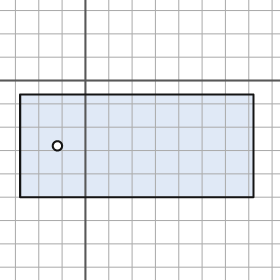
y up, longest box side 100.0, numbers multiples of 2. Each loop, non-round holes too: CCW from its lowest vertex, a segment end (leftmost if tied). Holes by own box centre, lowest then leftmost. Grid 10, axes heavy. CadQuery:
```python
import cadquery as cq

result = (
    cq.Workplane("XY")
    .moveTo(-28.0, -50.0)
    .lineTo(72.0, -50.0)
    .lineTo(72.0, -6.0)
    .lineTo(-28.0, -6.0)
    .close()
    .moveTo(-12.0, -28.0)
    .circle(2.0)
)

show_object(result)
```